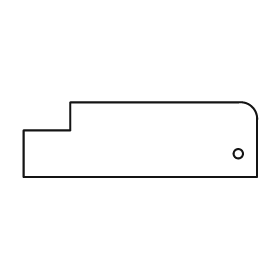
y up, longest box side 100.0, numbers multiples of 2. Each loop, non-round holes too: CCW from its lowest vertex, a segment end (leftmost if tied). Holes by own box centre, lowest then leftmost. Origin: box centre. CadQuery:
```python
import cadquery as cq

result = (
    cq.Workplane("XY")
    .moveTo(-50.0, -16.0)
    .lineTo(50.0, -16.0)
    .lineTo(50.0, 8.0)
    .threePointArc((48.0, 14.0), (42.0, 16.0))
    .lineTo(-30.0, 16.0)
    .lineTo(-30.0, 4.0)
    .lineTo(-50.0, 4.0)
    .close()
    .moveTo(42.0, -6.0)
    .circle(2.0)
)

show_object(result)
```